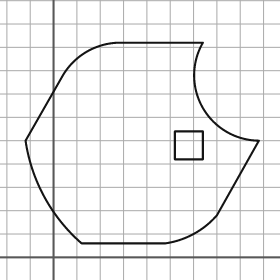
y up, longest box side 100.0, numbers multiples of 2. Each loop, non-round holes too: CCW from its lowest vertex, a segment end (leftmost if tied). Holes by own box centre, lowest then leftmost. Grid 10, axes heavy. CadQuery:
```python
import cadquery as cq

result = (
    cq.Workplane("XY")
    .moveTo(12.0, 6.0)
    .lineTo(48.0, 6.0)
    .threePointArc((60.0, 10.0), (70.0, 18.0))
    .lineTo(88.0, 50.0)
    .threePointArc((64.0, 64.0), (64.0, 92.0))
    .lineTo(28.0, 92.0)
    .threePointArc((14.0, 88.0), (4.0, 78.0))
    .lineTo(-12.0, 50.0)
    .threePointArc((-4.0, 26.0), (12.0, 6.0))
    .close()
    .moveTo(52.0, 42.0)
    .lineTo(64.0, 42.0)
    .lineTo(64.0, 54.0)
    .lineTo(52.0, 54.0)
    .close()
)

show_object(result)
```